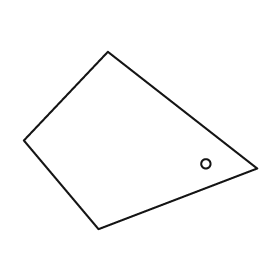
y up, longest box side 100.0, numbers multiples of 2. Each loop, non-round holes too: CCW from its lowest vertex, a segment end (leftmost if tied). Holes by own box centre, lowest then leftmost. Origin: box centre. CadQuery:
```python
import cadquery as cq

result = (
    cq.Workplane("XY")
    .moveTo(-18.0, -38.0)
    .lineTo(50.0, -12.0)
    .lineTo(-14.0, 38.0)
    .lineTo(-50.0, 0.0)
    .close()
    .moveTo(28.0, -10.0)
    .circle(2.0)
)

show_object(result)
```